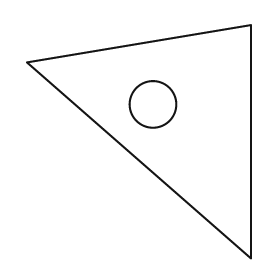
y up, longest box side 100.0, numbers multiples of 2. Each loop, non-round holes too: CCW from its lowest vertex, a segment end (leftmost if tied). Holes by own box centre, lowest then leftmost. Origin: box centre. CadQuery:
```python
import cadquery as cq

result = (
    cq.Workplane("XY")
    .moveTo(48.0, -50.0)
    .lineTo(48.0, 50.0)
    .lineTo(-48.0, 34.0)
    .close()
    .moveTo(6.0, 16.0)
    .circle(10.0)
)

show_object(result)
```